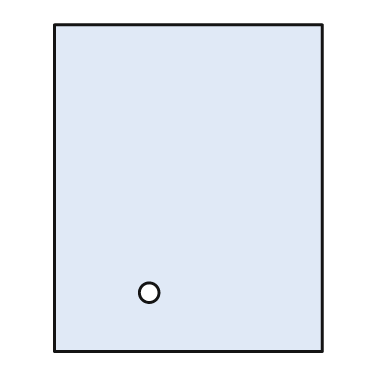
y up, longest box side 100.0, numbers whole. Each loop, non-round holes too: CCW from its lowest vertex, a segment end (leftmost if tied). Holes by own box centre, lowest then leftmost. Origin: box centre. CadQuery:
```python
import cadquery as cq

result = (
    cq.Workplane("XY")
    .moveTo(-41.0, -50.0)
    .lineTo(41.0, -50.0)
    .lineTo(41.0, 50.0)
    .lineTo(-41.0, 50.0)
    .close()
    .moveTo(-12.0, -32.0)
    .circle(3.0)
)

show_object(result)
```